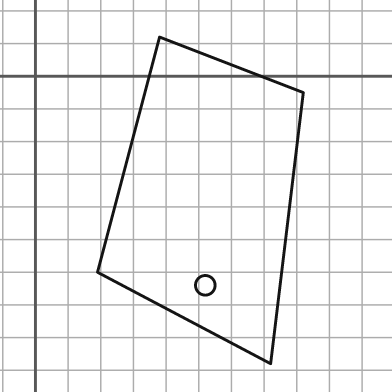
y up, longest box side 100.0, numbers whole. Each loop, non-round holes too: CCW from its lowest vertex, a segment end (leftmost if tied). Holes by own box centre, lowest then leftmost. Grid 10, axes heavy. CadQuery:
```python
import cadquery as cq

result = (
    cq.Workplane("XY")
    .moveTo(72.0, -88.0)
    .lineTo(82.0, -5.0)
    .lineTo(38.0, 12.0)
    .lineTo(19.0, -60.0)
    .close()
    .moveTo(52.0, -64.0)
    .circle(3.0)
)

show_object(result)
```